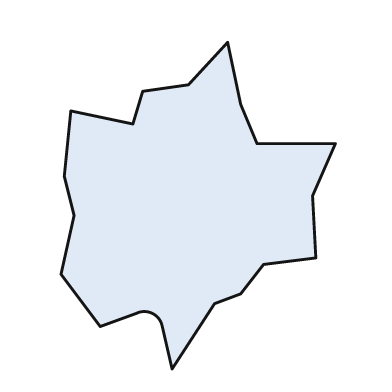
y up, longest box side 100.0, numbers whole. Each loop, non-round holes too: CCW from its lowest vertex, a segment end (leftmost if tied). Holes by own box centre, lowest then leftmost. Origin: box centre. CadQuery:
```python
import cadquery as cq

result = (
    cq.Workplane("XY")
    .moveTo(-8.0, -50.0)
    .lineTo(5.0, -30.0)
    .lineTo(13.0, -27.0)
    .lineTo(20.0, -18.0)
    .lineTo(36.0, -16.0)
    .lineTo(35.0, 3.0)
    .lineTo(42.0, 19.0)
    .lineTo(18.0, 19.0)
    .lineTo(13.0, 31.0)
    .lineTo(9.0, 50.0)
    .lineTo(-3.0, 37.0)
    .lineTo(-17.0, 35.0)
    .lineTo(-20.0, 25.0)
    .lineTo(-39.0, 29.0)
    .lineTo(-41.0, 9.0)
    .lineTo(-38.0, -3.0)
    .lineTo(-42.0, -21.0)
    .lineTo(-30.0, -37.0)
    .lineTo(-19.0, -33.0)
    .threePointArc((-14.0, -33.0), (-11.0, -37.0))
    .close()
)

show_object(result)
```